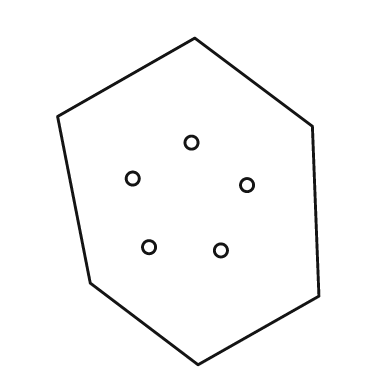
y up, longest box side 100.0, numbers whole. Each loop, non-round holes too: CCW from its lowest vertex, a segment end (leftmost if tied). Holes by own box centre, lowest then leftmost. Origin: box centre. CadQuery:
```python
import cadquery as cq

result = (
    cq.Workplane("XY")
    .moveTo(3.0, -50.0)
    .lineTo(40.0, -29.0)
    .lineTo(38.0, 23.0)
    .lineTo(2.0, 50.0)
    .lineTo(-40.0, 26.0)
    .lineTo(-30.0, -25.0)
    .close()
    .moveTo(10.0, -15.0)
    .circle(2.0)
    .moveTo(-12.0, -14.0)
    .circle(2.0)
    .moveTo(18.0, 5.0)
    .circle(2.0)
    .moveTo(-17.0, 7.0)
    .circle(2.0)
    .moveTo(1.0, 18.0)
    .circle(2.0)
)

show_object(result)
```